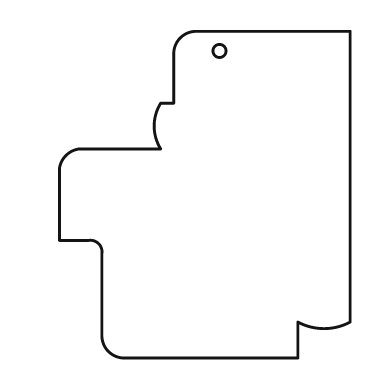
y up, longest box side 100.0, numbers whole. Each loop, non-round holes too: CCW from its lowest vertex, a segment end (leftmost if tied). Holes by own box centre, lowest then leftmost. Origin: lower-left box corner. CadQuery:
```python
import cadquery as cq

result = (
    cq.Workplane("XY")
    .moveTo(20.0, 0.0)
    .lineTo(73.0, 0.0)
    .lineTo(73.0, 11.0)
    .threePointArc((81.0, 9.0), (89.0, 11.0))
    .lineTo(89.0, 100.0)
    .lineTo(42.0, 100.0)
    .threePointArc((37.0, 98.0), (35.0, 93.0))
    .lineTo(35.0, 78.0)
    .lineTo(31.0, 78.0)
    .threePointArc((29.0, 71.0), (31.0, 64.0))
    .lineTo(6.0, 64.0)
    .threePointArc((2.0, 62.0), (0.0, 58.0))
    .lineTo(0.0, 36.0)
    .lineTo(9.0, 36.0)
    .threePointArc((12.0, 35.0), (13.0, 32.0))
    .lineTo(13.0, 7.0)
    .threePointArc((15.0, 2.0), (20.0, 0.0))
    .close()
    .moveTo(49.0, 94.0)
    .circle(2.0)
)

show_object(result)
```